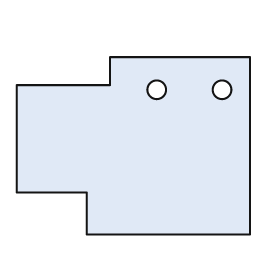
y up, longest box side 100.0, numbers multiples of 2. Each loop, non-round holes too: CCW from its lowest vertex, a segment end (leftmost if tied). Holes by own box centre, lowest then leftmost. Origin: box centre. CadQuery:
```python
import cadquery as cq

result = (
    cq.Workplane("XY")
    .moveTo(-20.0, -38.0)
    .lineTo(50.0, -38.0)
    .lineTo(50.0, 38.0)
    .lineTo(-10.0, 38.0)
    .lineTo(-10.0, 26.0)
    .lineTo(-50.0, 26.0)
    .lineTo(-50.0, -20.0)
    .lineTo(-20.0, -20.0)
    .close()
    .moveTo(10.0, 24.0)
    .circle(4.0)
    .moveTo(38.0, 24.0)
    .circle(4.0)
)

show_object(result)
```